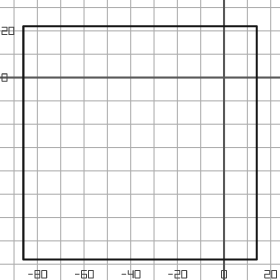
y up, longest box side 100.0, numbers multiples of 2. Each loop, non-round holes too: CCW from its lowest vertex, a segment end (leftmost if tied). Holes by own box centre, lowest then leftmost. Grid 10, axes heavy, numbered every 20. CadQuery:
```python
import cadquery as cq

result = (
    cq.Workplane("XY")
    .moveTo(-86.0, -78.0)
    .lineTo(14.0, -78.0)
    .lineTo(14.0, 22.0)
    .lineTo(-86.0, 22.0)
    .close()
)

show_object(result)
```